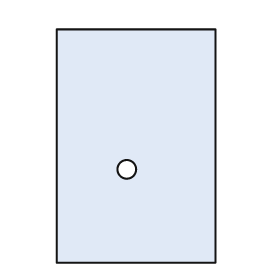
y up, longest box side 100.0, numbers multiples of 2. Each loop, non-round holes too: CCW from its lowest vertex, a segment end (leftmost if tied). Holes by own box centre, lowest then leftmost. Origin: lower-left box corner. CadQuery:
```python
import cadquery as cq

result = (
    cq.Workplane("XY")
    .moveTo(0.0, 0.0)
    .lineTo(68.0, 0.0)
    .lineTo(68.0, 100.0)
    .lineTo(0.0, 100.0)
    .close()
    .moveTo(30.0, 40.0)
    .circle(4.0)
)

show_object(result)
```